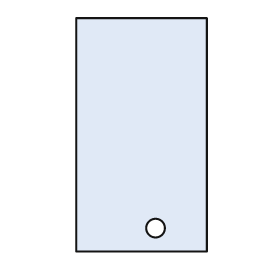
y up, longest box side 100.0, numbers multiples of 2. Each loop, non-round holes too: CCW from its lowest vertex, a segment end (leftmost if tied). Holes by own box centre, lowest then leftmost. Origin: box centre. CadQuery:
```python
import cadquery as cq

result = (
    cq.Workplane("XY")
    .moveTo(-28.0, -50.0)
    .lineTo(28.0, -50.0)
    .lineTo(28.0, 50.0)
    .lineTo(-28.0, 50.0)
    .close()
    .moveTo(6.0, -40.0)
    .circle(4.0)
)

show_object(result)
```